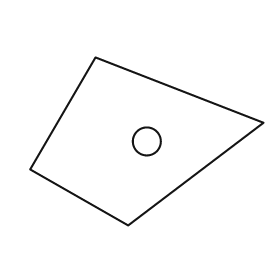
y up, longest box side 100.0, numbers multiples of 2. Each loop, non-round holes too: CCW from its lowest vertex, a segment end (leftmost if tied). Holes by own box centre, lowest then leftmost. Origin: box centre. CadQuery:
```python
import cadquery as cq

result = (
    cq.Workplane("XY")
    .moveTo(-8.0, -36.0)
    .lineTo(50.0, 8.0)
    .lineTo(-22.0, 36.0)
    .lineTo(-50.0, -12.0)
    .close()
    .moveTo(0.0, 0.0)
    .circle(6.0)
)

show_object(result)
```